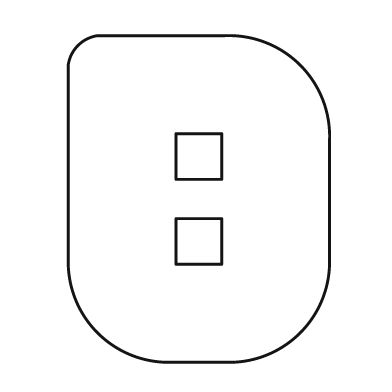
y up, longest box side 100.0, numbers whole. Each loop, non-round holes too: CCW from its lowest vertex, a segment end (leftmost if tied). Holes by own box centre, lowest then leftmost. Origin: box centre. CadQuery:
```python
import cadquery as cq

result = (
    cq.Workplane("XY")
    .moveTo(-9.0, -50.0)
    .lineTo(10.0, -50.0)
    .threePointArc((31.0, -41.0), (40.0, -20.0))
    .lineTo(40.0, 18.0)
    .threePointArc((31.0, 41.0), (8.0, 50.0))
    .lineTo(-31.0, 50.0)
    .threePointArc((-37.0, 47.0), (-40.0, 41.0))
    .lineTo(-40.0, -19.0)
    .threePointArc((-31.0, -41.0), (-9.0, -50.0))
    .close()
    .moveTo(-7.0, -20.0)
    .lineTo(7.0, -20.0)
    .lineTo(7.0, -6.0)
    .lineTo(-7.0, -6.0)
    .close()
    .moveTo(-7.0, 6.0)
    .lineTo(7.0, 6.0)
    .lineTo(7.0, 20.0)
    .lineTo(-7.0, 20.0)
    .close()
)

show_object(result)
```